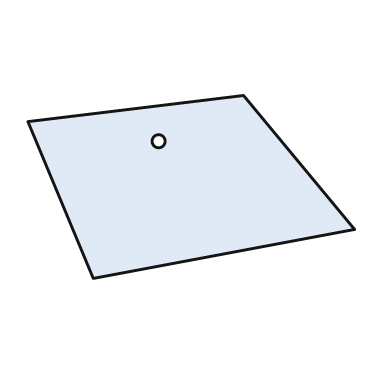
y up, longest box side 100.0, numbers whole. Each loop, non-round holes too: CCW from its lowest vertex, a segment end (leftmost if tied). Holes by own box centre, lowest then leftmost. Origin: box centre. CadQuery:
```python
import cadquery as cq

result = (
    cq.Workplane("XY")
    .moveTo(-30.0, -28.0)
    .lineTo(50.0, -13.0)
    .lineTo(16.0, 28.0)
    .lineTo(-50.0, 20.0)
    .close()
    .moveTo(-10.0, 14.0)
    .circle(2.0)
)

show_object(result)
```